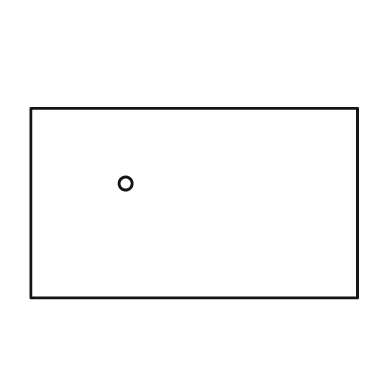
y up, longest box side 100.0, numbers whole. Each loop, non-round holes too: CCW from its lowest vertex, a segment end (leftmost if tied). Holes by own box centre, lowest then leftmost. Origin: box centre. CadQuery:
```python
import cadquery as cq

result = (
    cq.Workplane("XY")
    .moveTo(-50.0, -29.0)
    .lineTo(50.0, -29.0)
    .lineTo(50.0, 29.0)
    .lineTo(-50.0, 29.0)
    .close()
    .moveTo(-21.0, 6.0)
    .circle(2.0)
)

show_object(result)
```